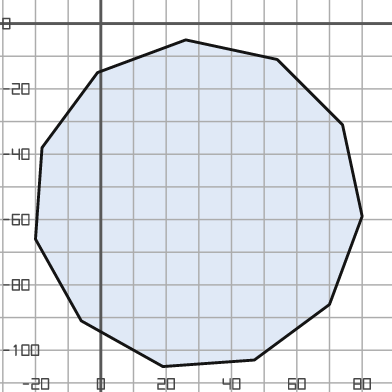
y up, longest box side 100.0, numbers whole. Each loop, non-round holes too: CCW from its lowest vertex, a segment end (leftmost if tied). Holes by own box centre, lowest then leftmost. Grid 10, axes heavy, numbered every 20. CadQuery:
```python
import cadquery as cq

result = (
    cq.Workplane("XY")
    .moveTo(19.0, -105.0)
    .lineTo(47.0, -103.0)
    .lineTo(70.0, -86.0)
    .lineTo(80.0, -59.0)
    .lineTo(74.0, -31.0)
    .lineTo(54.0, -11.0)
    .lineTo(26.0, -5.0)
    .lineTo(-1.0, -15.0)
    .lineTo(-18.0, -38.0)
    .lineTo(-20.0, -66.0)
    .lineTo(-6.0, -91.0)
    .close()
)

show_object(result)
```